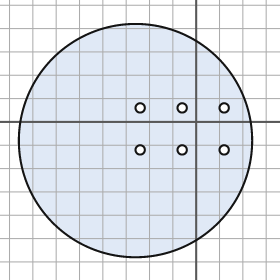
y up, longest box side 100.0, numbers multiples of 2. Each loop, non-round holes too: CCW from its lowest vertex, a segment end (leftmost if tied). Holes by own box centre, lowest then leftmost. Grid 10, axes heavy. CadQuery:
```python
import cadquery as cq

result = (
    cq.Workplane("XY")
    .moveTo(-26.0, -8.0)
    .circle(50.0)
    .moveTo(-24.0, -12.0)
    .circle(2.0)
    .moveTo(-6.0, -12.0)
    .circle(2.0)
    .moveTo(12.0, -12.0)
    .circle(2.0)
    .moveTo(-24.0, 6.0)
    .circle(2.0)
    .moveTo(-6.0, 6.0)
    .circle(2.0)
    .moveTo(12.0, 6.0)
    .circle(2.0)
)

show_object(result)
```